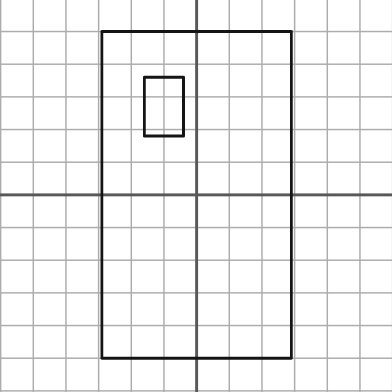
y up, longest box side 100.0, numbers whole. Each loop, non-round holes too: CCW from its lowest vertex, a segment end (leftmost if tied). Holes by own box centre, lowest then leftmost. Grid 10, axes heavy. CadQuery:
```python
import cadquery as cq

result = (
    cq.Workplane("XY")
    .moveTo(-29.0, -50.0)
    .lineTo(29.0, -50.0)
    .lineTo(29.0, 50.0)
    .lineTo(-29.0, 50.0)
    .close()
    .moveTo(-16.0, 18.0)
    .lineTo(-4.0, 18.0)
    .lineTo(-4.0, 36.0)
    .lineTo(-16.0, 36.0)
    .close()
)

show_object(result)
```